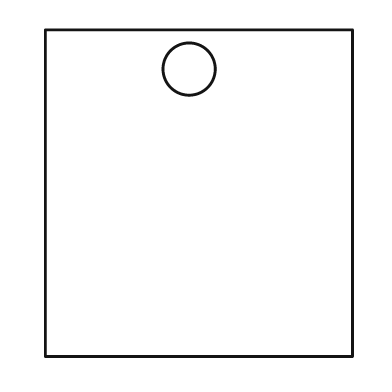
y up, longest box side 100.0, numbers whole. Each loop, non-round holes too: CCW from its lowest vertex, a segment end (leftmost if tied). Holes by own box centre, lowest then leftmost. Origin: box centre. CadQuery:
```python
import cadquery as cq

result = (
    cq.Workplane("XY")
    .moveTo(-47.0, -50.0)
    .lineTo(47.0, -50.0)
    .lineTo(47.0, 50.0)
    .lineTo(-47.0, 50.0)
    .close()
    .moveTo(-3.0, 38.0)
    .circle(8.0)
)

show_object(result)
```